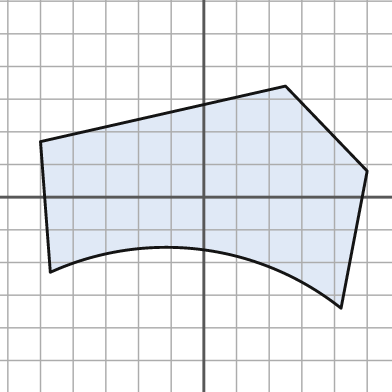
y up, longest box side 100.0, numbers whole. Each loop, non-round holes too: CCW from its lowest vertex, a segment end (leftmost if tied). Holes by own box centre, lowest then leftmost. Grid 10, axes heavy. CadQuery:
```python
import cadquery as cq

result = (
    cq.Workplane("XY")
    .moveTo(42.0, -34.0)
    .lineTo(50.0, 8.0)
    .lineTo(25.0, 34.0)
    .lineTo(-50.0, 17.0)
    .lineTo(-47.0, -23.0)
    .threePointArc((-1.0, -16.0), (42.0, -34.0))
    .close()
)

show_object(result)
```